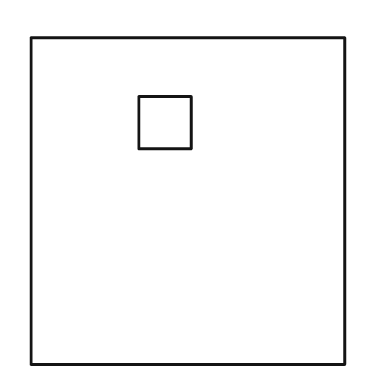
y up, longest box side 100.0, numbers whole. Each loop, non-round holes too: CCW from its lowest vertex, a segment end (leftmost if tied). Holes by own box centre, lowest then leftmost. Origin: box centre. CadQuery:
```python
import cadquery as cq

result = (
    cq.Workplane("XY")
    .moveTo(-48.0, -50.0)
    .lineTo(48.0, -50.0)
    .lineTo(48.0, 50.0)
    .lineTo(-48.0, 50.0)
    .close()
    .moveTo(-15.0, 16.0)
    .lineTo(1.0, 16.0)
    .lineTo(1.0, 32.0)
    .lineTo(-15.0, 32.0)
    .close()
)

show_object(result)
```